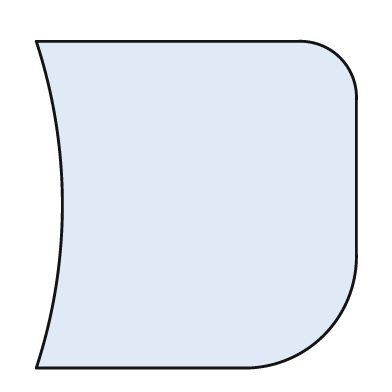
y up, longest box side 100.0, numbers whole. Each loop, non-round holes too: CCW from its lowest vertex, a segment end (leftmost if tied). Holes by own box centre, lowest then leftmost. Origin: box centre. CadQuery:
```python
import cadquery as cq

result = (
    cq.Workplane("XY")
    .moveTo(-49.0, -50.0)
    .lineTo(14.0, -50.0)
    .threePointArc((39.0, -40.0), (49.0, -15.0))
    .lineTo(49.0, 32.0)
    .threePointArc((44.0, 45.0), (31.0, 50.0))
    .lineTo(-49.0, 50.0)
    .threePointArc((-41.0, 0.0), (-49.0, -50.0))
    .close()
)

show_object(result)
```